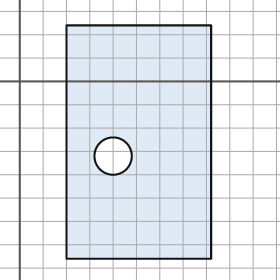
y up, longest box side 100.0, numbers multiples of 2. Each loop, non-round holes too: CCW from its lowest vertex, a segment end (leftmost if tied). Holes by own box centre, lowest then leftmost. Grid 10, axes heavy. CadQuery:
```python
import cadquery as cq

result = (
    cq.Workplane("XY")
    .moveTo(20.0, -76.0)
    .lineTo(82.0, -76.0)
    .lineTo(82.0, 24.0)
    .lineTo(20.0, 24.0)
    .close()
    .moveTo(40.0, -32.0)
    .circle(8.0)
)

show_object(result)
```